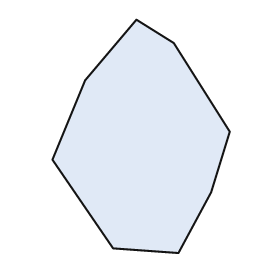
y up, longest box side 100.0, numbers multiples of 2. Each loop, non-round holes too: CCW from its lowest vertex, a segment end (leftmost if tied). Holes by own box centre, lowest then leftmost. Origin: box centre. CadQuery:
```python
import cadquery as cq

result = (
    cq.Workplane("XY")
    .moveTo(16.0, -50.0)
    .lineTo(30.0, -24.0)
    .lineTo(38.0, 2.0)
    .lineTo(14.0, 40.0)
    .lineTo(-2.0, 50.0)
    .lineTo(-24.0, 24.0)
    .lineTo(-38.0, -10.0)
    .lineTo(-12.0, -48.0)
    .close()
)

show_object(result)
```